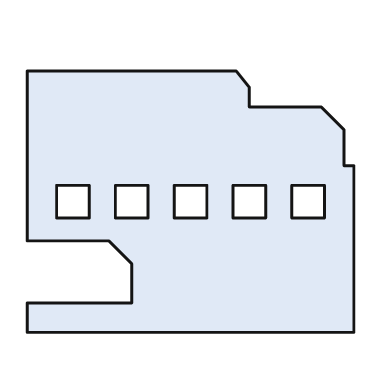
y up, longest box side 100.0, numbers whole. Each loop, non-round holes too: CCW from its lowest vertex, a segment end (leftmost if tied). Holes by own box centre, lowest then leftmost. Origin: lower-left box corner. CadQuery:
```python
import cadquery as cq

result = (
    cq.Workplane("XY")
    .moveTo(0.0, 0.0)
    .lineTo(100.0, 0.0)
    .lineTo(100.0, 51.0)
    .lineTo(97.0, 51.0)
    .lineTo(97.0, 62.0)
    .lineTo(90.0, 69.0)
    .lineTo(68.0, 69.0)
    .lineTo(68.0, 75.0)
    .lineTo(64.0, 80.0)
    .lineTo(0.0, 80.0)
    .lineTo(0.0, 28.0)
    .lineTo(25.0, 28.0)
    .lineTo(32.0, 21.0)
    .lineTo(32.0, 9.0)
    .lineTo(0.0, 9.0)
    .close()
    .moveTo(9.0, 35.0)
    .lineTo(19.0, 35.0)
    .lineTo(19.0, 45.0)
    .lineTo(9.0, 45.0)
    .close()
    .moveTo(27.0, 35.0)
    .lineTo(37.0, 35.0)
    .lineTo(37.0, 45.0)
    .lineTo(27.0, 45.0)
    .close()
    .moveTo(45.0, 35.0)
    .lineTo(55.0, 35.0)
    .lineTo(55.0, 45.0)
    .lineTo(45.0, 45.0)
    .close()
    .moveTo(63.0, 35.0)
    .lineTo(73.0, 35.0)
    .lineTo(73.0, 45.0)
    .lineTo(63.0, 45.0)
    .close()
    .moveTo(81.0, 35.0)
    .lineTo(91.0, 35.0)
    .lineTo(91.0, 45.0)
    .lineTo(81.0, 45.0)
    .close()
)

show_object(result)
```